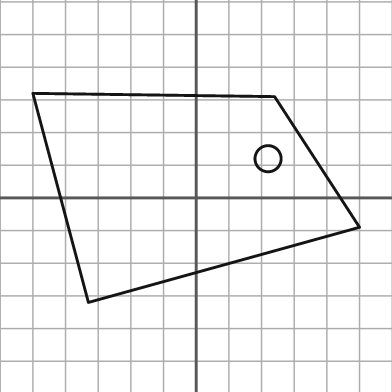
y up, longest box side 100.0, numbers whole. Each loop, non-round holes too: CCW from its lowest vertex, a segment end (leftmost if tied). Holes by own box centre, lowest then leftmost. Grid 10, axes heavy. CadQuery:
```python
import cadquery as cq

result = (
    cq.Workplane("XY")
    .moveTo(-33.0, -32.0)
    .lineTo(50.0, -9.0)
    .lineTo(24.0, 31.0)
    .lineTo(-50.0, 32.0)
    .close()
    .moveTo(22.0, 12.0)
    .circle(4.0)
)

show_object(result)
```